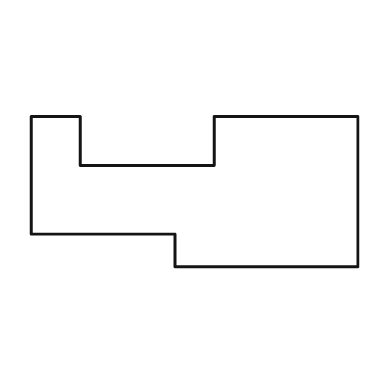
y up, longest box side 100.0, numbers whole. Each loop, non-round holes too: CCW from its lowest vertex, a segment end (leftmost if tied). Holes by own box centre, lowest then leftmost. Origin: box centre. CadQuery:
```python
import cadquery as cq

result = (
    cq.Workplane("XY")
    .moveTo(-6.0, -23.0)
    .lineTo(50.0, -23.0)
    .lineTo(50.0, 23.0)
    .lineTo(6.0, 23.0)
    .lineTo(6.0, 8.0)
    .lineTo(-35.0, 8.0)
    .lineTo(-35.0, 23.0)
    .lineTo(-50.0, 23.0)
    .lineTo(-50.0, -13.0)
    .lineTo(-6.0, -13.0)
    .close()
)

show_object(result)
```